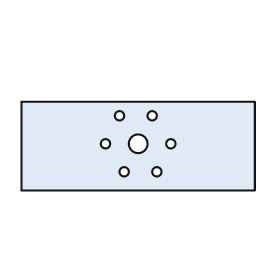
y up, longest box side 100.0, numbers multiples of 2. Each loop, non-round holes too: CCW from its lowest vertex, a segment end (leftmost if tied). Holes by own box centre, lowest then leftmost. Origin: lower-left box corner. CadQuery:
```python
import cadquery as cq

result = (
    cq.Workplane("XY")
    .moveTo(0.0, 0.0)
    .lineTo(100.0, 0.0)
    .lineTo(100.0, 38.0)
    .lineTo(0.0, 38.0)
    .close()
    .moveTo(44.0, 8.0)
    .circle(2.0)
    .moveTo(58.0, 8.0)
    .circle(2.0)
    .moveTo(36.0, 20.0)
    .circle(2.0)
    .moveTo(50.0, 20.0)
    .circle(4.0)
    .moveTo(64.0, 20.0)
    .circle(2.0)
    .moveTo(42.0, 32.0)
    .circle(2.0)
    .moveTo(56.0, 32.0)
    .circle(2.0)
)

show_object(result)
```